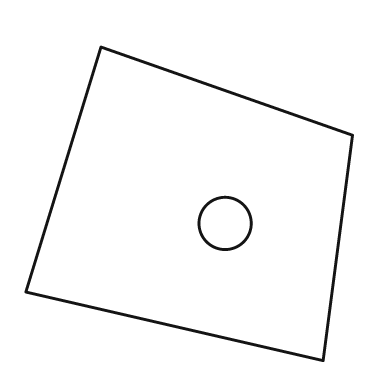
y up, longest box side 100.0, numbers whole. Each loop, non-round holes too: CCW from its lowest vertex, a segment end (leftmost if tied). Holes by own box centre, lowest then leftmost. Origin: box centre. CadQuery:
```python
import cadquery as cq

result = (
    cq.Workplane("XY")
    .moveTo(41.0, -48.0)
    .lineTo(50.0, 21.0)
    .lineTo(-27.0, 48.0)
    .lineTo(-50.0, -27.0)
    .close()
    .moveTo(11.0, -6.0)
    .circle(8.0)
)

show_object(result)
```